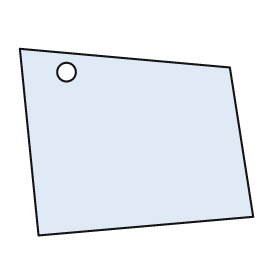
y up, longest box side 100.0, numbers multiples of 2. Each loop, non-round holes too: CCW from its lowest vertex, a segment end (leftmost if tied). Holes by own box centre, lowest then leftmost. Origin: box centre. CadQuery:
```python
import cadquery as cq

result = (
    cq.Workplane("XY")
    .moveTo(-42.0, -40.0)
    .lineTo(50.0, -32.0)
    .lineTo(40.0, 32.0)
    .lineTo(-50.0, 40.0)
    .close()
    .moveTo(-30.0, 30.0)
    .circle(4.0)
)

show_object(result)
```